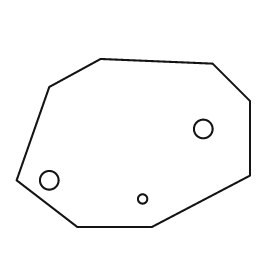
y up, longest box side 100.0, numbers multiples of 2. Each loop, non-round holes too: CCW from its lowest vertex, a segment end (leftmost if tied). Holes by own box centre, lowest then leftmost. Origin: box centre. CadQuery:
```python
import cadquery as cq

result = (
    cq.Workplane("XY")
    .moveTo(-24.0, -36.0)
    .lineTo(8.0, -36.0)
    .lineTo(50.0, -14.0)
    .lineTo(50.0, 18.0)
    .lineTo(34.0, 34.0)
    .lineTo(-14.0, 36.0)
    .lineTo(-36.0, 24.0)
    .lineTo(-50.0, -16.0)
    .close()
    .moveTo(4.0, -24.0)
    .circle(2.0)
    .moveTo(-36.0, -16.0)
    .circle(4.0)
    .moveTo(30.0, 6.0)
    .circle(4.0)
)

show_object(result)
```